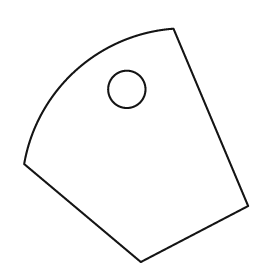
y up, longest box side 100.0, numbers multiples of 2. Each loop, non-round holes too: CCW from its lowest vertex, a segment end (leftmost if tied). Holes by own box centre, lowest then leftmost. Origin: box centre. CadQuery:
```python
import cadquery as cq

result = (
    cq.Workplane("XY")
    .moveTo(2.0, -50.0)
    .lineTo(48.0, -26.0)
    .lineTo(16.0, 50.0)
    .threePointArc((-26.0, 32.0), (-48.0, -8.0))
    .close()
    .moveTo(-4.0, 24.0)
    .circle(8.0)
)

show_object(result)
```